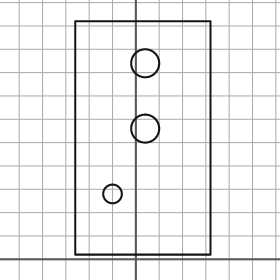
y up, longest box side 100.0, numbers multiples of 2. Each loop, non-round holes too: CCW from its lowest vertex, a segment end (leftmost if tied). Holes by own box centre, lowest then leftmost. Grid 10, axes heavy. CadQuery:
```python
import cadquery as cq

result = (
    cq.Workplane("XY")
    .moveTo(-26.0, 2.0)
    .lineTo(32.0, 2.0)
    .lineTo(32.0, 102.0)
    .lineTo(-26.0, 102.0)
    .close()
    .moveTo(-10.0, 28.0)
    .circle(4.0)
    .moveTo(4.0, 56.0)
    .circle(6.0)
    .moveTo(4.0, 84.0)
    .circle(6.0)
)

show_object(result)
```